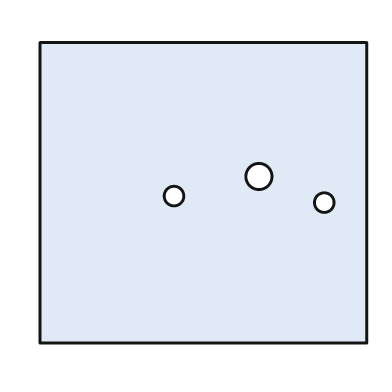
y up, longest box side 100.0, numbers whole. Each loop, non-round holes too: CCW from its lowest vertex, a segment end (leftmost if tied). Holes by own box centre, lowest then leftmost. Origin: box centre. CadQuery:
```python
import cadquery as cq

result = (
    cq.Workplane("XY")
    .moveTo(-50.0, -46.0)
    .lineTo(50.0, -46.0)
    .lineTo(50.0, 46.0)
    .lineTo(-50.0, 46.0)
    .close()
    .moveTo(37.0, -3.0)
    .circle(3.0)
    .moveTo(-9.0, -1.0)
    .circle(3.0)
    .moveTo(17.0, 5.0)
    .circle(4.0)
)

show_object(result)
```